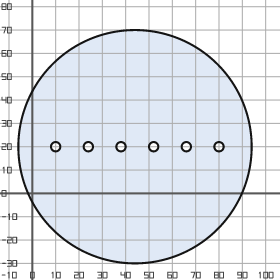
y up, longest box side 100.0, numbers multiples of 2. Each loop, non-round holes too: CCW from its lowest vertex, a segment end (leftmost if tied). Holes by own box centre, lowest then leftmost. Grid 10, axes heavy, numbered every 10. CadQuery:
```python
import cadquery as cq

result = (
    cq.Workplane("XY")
    .moveTo(44.0, 20.0)
    .circle(50.0)
    .moveTo(10.0, 20.0)
    .circle(2.0)
    .moveTo(24.0, 20.0)
    .circle(2.0)
    .moveTo(38.0, 20.0)
    .circle(2.0)
    .moveTo(52.0, 20.0)
    .circle(2.0)
    .moveTo(66.0, 20.0)
    .circle(2.0)
    .moveTo(80.0, 20.0)
    .circle(2.0)
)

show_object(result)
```